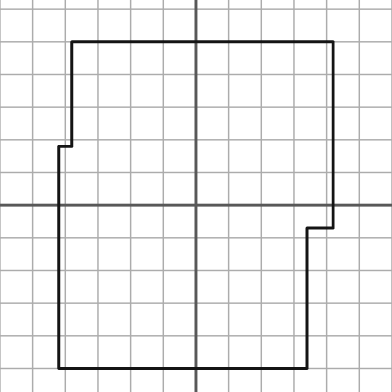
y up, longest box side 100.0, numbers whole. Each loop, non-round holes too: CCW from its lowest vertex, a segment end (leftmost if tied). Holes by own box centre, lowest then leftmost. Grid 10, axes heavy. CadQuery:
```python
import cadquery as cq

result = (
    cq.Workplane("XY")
    .moveTo(-42.0, -50.0)
    .lineTo(34.0, -50.0)
    .lineTo(34.0, -7.0)
    .lineTo(42.0, -7.0)
    .lineTo(42.0, 50.0)
    .lineTo(-38.0, 50.0)
    .lineTo(-38.0, 18.0)
    .lineTo(-42.0, 18.0)
    .close()
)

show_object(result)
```